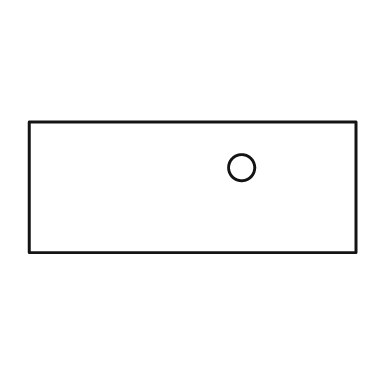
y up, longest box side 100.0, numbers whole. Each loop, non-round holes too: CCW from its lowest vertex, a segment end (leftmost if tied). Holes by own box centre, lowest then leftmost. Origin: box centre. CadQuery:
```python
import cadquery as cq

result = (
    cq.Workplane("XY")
    .moveTo(-50.0, -20.0)
    .lineTo(50.0, -20.0)
    .lineTo(50.0, 20.0)
    .lineTo(-50.0, 20.0)
    .close()
    .moveTo(15.0, 6.0)
    .circle(4.0)
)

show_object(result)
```